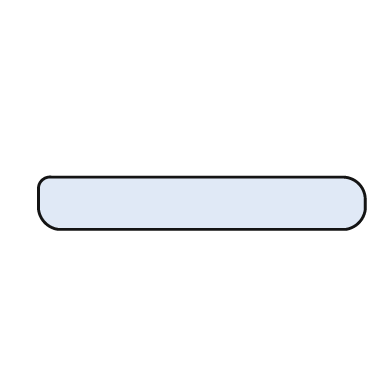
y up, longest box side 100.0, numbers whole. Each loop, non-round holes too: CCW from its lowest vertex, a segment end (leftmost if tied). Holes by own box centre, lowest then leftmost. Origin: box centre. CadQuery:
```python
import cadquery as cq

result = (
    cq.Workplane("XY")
    .moveTo(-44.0, -8.0)
    .lineTo(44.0, -8.0)
    .threePointArc((48.0, -6.0), (50.0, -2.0))
    .lineTo(50.0, 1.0)
    .threePointArc((48.0, 6.0), (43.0, 8.0))
    .lineTo(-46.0, 8.0)
    .threePointArc((-49.0, 7.0), (-50.0, 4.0))
    .lineTo(-50.0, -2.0)
    .threePointArc((-48.0, -6.0), (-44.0, -8.0))
    .close()
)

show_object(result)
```